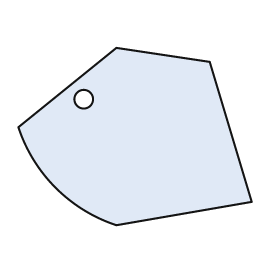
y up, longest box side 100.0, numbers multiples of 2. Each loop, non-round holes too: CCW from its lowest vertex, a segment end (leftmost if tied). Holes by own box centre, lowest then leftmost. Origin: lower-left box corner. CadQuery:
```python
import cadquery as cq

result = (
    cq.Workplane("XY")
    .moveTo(42.0, 0.0)
    .lineTo(100.0, 10.0)
    .lineTo(82.0, 70.0)
    .lineTo(42.0, 76.0)
    .lineTo(0.0, 42.0)
    .threePointArc((16.0, 16.0), (42.0, 0.0))
    .close()
    .moveTo(28.0, 54.0)
    .circle(4.0)
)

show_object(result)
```